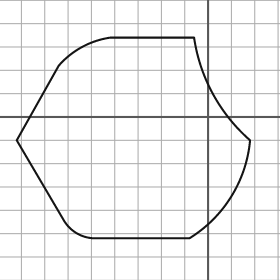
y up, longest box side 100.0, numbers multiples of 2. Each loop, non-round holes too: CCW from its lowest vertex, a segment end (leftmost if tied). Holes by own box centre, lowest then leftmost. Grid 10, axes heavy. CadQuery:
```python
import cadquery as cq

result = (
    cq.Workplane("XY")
    .moveTo(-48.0, -52.0)
    .lineTo(-8.0, -52.0)
    .threePointArc((10.0, -34.0), (18.0, -10.0))
    .threePointArc((2.0, 10.0), (-6.0, 34.0))
    .lineTo(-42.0, 34.0)
    .threePointArc((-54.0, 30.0), (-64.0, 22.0))
    .lineTo(-82.0, -10.0)
    .lineTo(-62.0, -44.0)
    .threePointArc((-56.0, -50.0), (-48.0, -52.0))
    .close()
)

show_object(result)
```